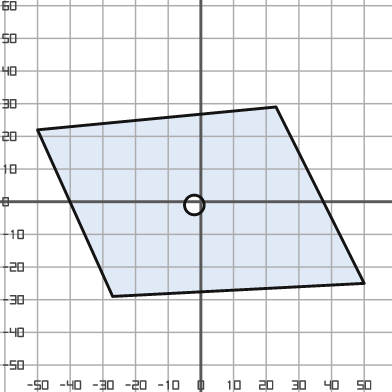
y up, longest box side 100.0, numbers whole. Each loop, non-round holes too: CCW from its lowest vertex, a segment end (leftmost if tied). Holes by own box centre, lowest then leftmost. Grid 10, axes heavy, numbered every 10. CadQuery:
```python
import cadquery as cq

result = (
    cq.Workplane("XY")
    .moveTo(-27.0, -29.0)
    .lineTo(50.0, -25.0)
    .lineTo(23.0, 29.0)
    .lineTo(-50.0, 22.0)
    .close()
    .moveTo(-2.0, -1.0)
    .circle(3.0)
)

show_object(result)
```